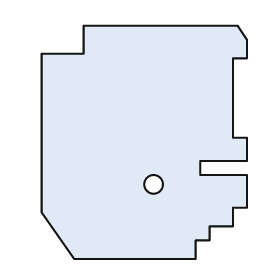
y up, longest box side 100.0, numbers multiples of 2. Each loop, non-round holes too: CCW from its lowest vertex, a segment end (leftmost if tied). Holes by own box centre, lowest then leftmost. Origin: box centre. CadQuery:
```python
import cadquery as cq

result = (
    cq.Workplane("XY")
    .moveTo(-30.0, -50.0)
    .lineTo(22.0, -50.0)
    .lineTo(22.0, -42.0)
    .lineTo(28.0, -42.0)
    .lineTo(28.0, -36.0)
    .lineTo(38.0, -36.0)
    .lineTo(38.0, -28.0)
    .lineTo(44.0, -28.0)
    .lineTo(44.0, -14.0)
    .lineTo(24.0, -14.0)
    .lineTo(24.0, -8.0)
    .lineTo(44.0, -8.0)
    .lineTo(44.0, 2.0)
    .lineTo(38.0, 2.0)
    .lineTo(38.0, 36.0)
    .lineTo(44.0, 36.0)
    .lineTo(44.0, 44.0)
    .lineTo(40.0, 50.0)
    .lineTo(-26.0, 50.0)
    .lineTo(-26.0, 38.0)
    .lineTo(-44.0, 38.0)
    .lineTo(-44.0, -30.0)
    .close()
    .moveTo(4.0, -18.0)
    .circle(4.0)
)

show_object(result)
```